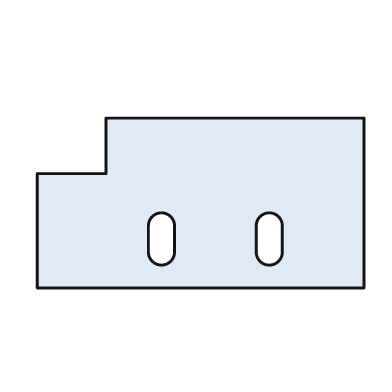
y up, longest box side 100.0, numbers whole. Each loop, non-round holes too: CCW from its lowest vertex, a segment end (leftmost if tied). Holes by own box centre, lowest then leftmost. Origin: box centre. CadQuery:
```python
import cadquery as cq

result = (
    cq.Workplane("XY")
    .moveTo(-50.0, -26.0)
    .lineTo(50.0, -26.0)
    .lineTo(50.0, 26.0)
    .lineTo(-29.0, 26.0)
    .lineTo(-29.0, 9.0)
    .lineTo(-50.0, 9.0)
    .close()
    .moveTo(-16.0, -15.0)
    .threePointArc((-12.0, -19.0), (-8.0, -15.0))
    .lineTo(-8.0, -7.0)
    .threePointArc((-12.0, -3.0), (-16.0, -7.0))
    .close()
    .moveTo(17.0, -15.0)
    .threePointArc((21.0, -19.0), (25.0, -15.0))
    .lineTo(25.0, -7.0)
    .threePointArc((21.0, -3.0), (17.0, -7.0))
    .close()
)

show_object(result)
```